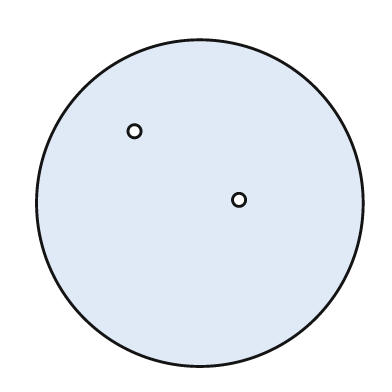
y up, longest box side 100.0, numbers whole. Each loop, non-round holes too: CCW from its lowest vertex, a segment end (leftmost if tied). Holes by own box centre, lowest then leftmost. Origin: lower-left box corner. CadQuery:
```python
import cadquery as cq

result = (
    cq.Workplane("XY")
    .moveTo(50.0, 50.0)
    .circle(50.0)
    .moveTo(62.0, 51.0)
    .circle(2.0)
    .moveTo(30.0, 72.0)
    .circle(2.0)
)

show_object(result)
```